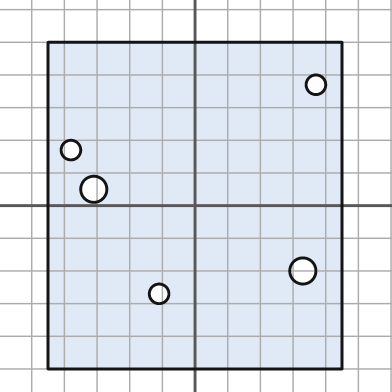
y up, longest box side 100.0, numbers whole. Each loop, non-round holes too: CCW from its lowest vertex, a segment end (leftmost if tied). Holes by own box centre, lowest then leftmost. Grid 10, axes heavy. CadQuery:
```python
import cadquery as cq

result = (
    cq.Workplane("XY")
    .moveTo(-45.0, -50.0)
    .lineTo(45.0, -50.0)
    .lineTo(45.0, 50.0)
    .lineTo(-45.0, 50.0)
    .close()
    .moveTo(-11.0, -27.0)
    .circle(3.0)
    .moveTo(33.0, -20.0)
    .circle(4.0)
    .moveTo(-31.0, 5.0)
    .circle(4.0)
    .moveTo(-38.0, 17.0)
    .circle(3.0)
    .moveTo(37.0, 37.0)
    .circle(3.0)
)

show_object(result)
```